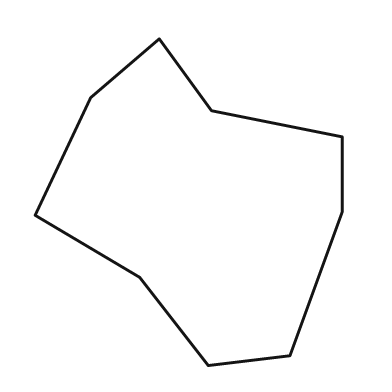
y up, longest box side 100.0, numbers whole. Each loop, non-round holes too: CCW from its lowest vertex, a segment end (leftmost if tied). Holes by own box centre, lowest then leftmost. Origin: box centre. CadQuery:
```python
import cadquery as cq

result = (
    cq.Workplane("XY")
    .moveTo(6.0, -50.0)
    .lineTo(31.0, -47.0)
    .lineTo(47.0, -3.0)
    .lineTo(47.0, 20.0)
    .lineTo(7.0, 28.0)
    .lineTo(-9.0, 50.0)
    .lineTo(-30.0, 32.0)
    .lineTo(-47.0, -4.0)
    .lineTo(-15.0, -23.0)
    .close()
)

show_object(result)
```